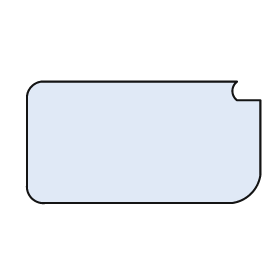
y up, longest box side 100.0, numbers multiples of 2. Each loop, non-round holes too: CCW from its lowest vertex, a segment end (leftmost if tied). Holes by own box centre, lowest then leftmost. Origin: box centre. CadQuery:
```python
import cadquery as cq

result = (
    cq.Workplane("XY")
    .moveTo(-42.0, -26.0)
    .lineTo(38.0, -26.0)
    .threePointArc((46.0, -22.0), (50.0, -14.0))
    .lineTo(50.0, 18.0)
    .lineTo(40.0, 18.0)
    .threePointArc((38.0, 22.0), (40.0, 26.0))
    .lineTo(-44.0, 26.0)
    .threePointArc((-48.0, 24.0), (-50.0, 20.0))
    .lineTo(-50.0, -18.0)
    .threePointArc((-48.0, -24.0), (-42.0, -26.0))
    .close()
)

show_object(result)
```